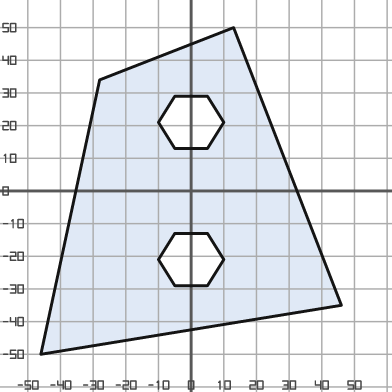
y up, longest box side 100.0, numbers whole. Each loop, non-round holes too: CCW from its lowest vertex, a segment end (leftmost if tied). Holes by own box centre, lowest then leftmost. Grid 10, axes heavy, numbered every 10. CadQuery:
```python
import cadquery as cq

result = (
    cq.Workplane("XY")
    .moveTo(-46.0, -50.0)
    .lineTo(46.0, -35.0)
    .lineTo(13.0, 50.0)
    .lineTo(-28.0, 34.0)
    .close()
    .moveTo(-5.0, -29.0)
    .lineTo(5.0, -29.0)
    .lineTo(10.0, -21.0)
    .lineTo(5.0, -13.0)
    .lineTo(-5.0, -13.0)
    .lineTo(-10.0, -21.0)
    .close()
    .moveTo(-5.0, 13.0)
    .lineTo(5.0, 13.0)
    .lineTo(10.0, 21.0)
    .lineTo(5.0, 29.0)
    .lineTo(-5.0, 29.0)
    .lineTo(-10.0, 21.0)
    .close()
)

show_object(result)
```